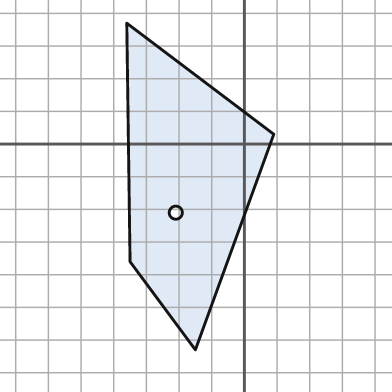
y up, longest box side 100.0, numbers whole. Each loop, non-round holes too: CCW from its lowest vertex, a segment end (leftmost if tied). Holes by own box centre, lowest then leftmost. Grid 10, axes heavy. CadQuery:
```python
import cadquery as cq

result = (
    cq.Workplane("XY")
    .moveTo(-15.0, -63.0)
    .lineTo(9.0, 3.0)
    .lineTo(-36.0, 37.0)
    .lineTo(-35.0, -36.0)
    .close()
    .moveTo(-21.0, -21.0)
    .circle(2.0)
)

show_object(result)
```